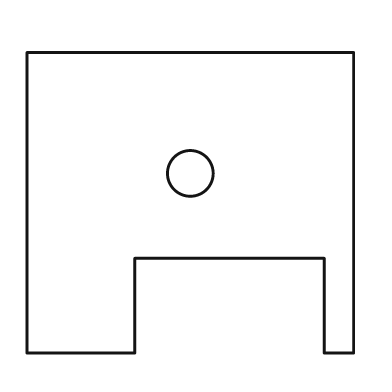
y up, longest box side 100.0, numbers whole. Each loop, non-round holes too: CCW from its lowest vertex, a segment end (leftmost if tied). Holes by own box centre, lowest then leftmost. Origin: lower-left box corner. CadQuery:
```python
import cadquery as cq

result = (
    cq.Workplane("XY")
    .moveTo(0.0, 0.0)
    .lineTo(33.0, 0.0)
    .lineTo(33.0, 29.0)
    .lineTo(91.0, 29.0)
    .lineTo(91.0, 0.0)
    .lineTo(100.0, 0.0)
    .lineTo(100.0, 92.0)
    .lineTo(0.0, 92.0)
    .close()
    .moveTo(50.0, 55.0)
    .circle(7.0)
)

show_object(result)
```